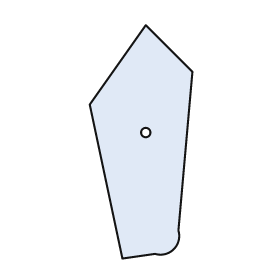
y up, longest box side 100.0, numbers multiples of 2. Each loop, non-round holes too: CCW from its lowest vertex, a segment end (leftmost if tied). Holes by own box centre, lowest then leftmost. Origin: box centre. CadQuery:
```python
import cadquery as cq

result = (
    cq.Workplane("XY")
    .moveTo(-8.0, -50.0)
    .lineTo(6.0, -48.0)
    .threePointArc((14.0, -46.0), (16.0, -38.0))
    .lineTo(22.0, 30.0)
    .lineTo(2.0, 50.0)
    .lineTo(-22.0, 16.0)
    .close()
    .moveTo(2.0, 4.0)
    .circle(2.0)
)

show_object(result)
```